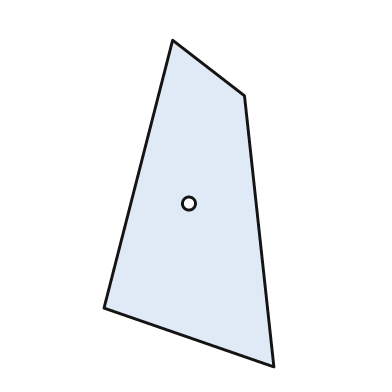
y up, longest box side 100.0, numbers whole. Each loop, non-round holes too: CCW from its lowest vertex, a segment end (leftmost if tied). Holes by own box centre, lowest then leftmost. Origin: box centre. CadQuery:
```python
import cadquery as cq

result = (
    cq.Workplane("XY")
    .moveTo(26.0, -50.0)
    .lineTo(17.0, 33.0)
    .lineTo(-5.0, 50.0)
    .lineTo(-26.0, -32.0)
    .close()
    .moveTo(0.0, 0.0)
    .circle(2.0)
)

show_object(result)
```